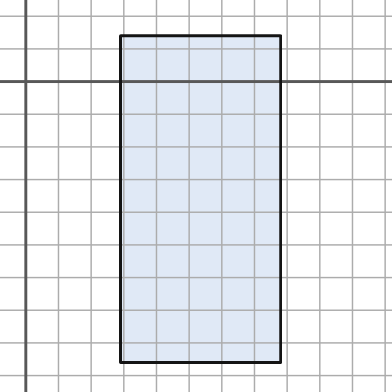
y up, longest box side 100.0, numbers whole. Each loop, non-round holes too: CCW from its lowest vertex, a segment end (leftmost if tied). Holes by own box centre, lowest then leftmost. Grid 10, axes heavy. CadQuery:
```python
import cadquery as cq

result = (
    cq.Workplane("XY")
    .moveTo(29.0, -86.0)
    .lineTo(78.0, -86.0)
    .lineTo(78.0, 14.0)
    .lineTo(29.0, 14.0)
    .close()
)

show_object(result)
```